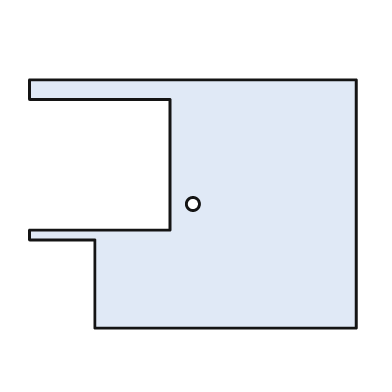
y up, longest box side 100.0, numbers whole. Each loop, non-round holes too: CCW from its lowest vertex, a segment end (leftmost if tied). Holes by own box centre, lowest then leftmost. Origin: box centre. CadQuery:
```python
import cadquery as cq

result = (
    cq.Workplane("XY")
    .moveTo(-30.0, -38.0)
    .lineTo(50.0, -38.0)
    .lineTo(50.0, 38.0)
    .lineTo(-50.0, 38.0)
    .lineTo(-50.0, 32.0)
    .lineTo(-7.0, 32.0)
    .lineTo(-7.0, -8.0)
    .lineTo(-50.0, -8.0)
    .lineTo(-50.0, -11.0)
    .lineTo(-30.0, -11.0)
    .close()
    .moveTo(0.0, 0.0)
    .circle(2.0)
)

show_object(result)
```